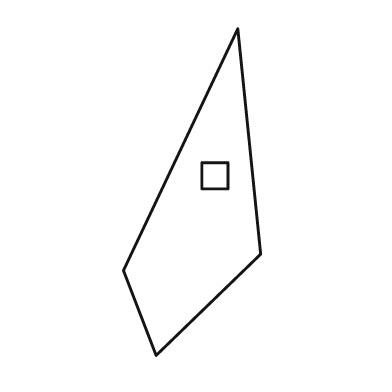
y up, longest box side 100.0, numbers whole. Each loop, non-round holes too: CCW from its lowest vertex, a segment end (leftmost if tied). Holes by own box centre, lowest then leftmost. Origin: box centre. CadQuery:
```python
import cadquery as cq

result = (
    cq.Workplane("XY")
    .moveTo(-11.0, -50.0)
    .lineTo(21.0, -19.0)
    .lineTo(14.0, 50.0)
    .lineTo(-21.0, -24.0)
    .close()
    .moveTo(3.0, 1.0)
    .lineTo(11.0, 1.0)
    .lineTo(11.0, 9.0)
    .lineTo(3.0, 9.0)
    .close()
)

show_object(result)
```